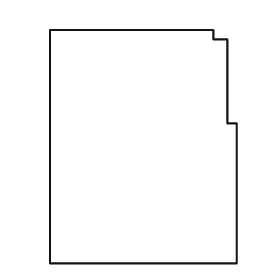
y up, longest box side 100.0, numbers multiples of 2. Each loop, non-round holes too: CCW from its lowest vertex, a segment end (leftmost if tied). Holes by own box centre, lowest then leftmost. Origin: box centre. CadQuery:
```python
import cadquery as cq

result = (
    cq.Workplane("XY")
    .moveTo(-40.0, -50.0)
    .lineTo(40.0, -50.0)
    .lineTo(40.0, 10.0)
    .lineTo(36.0, 10.0)
    .lineTo(36.0, 46.0)
    .lineTo(30.0, 46.0)
    .lineTo(30.0, 50.0)
    .lineTo(-40.0, 50.0)
    .close()
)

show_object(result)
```